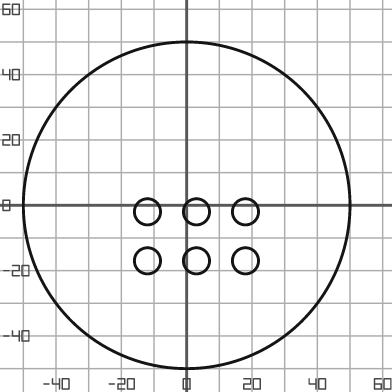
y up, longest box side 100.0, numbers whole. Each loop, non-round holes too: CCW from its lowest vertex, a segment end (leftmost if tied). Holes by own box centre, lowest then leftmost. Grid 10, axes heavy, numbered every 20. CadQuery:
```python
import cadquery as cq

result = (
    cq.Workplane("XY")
    .moveTo(0.0, 0.0)
    .circle(50.0)
    .moveTo(-12.0, -17.0)
    .circle(4.0)
    .moveTo(3.0, -17.0)
    .circle(4.0)
    .moveTo(18.0, -17.0)
    .circle(4.0)
    .moveTo(-12.0, -2.0)
    .circle(4.0)
    .moveTo(3.0, -2.0)
    .circle(4.0)
    .moveTo(18.0, -2.0)
    .circle(4.0)
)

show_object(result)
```